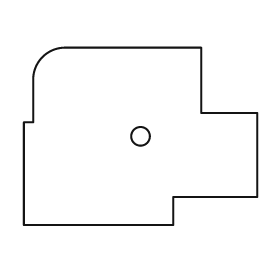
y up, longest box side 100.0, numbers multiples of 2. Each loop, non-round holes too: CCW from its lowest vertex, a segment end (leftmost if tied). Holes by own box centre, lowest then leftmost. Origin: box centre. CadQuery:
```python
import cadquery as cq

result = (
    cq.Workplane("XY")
    .moveTo(-50.0, -38.0)
    .lineTo(14.0, -38.0)
    .lineTo(14.0, -26.0)
    .lineTo(50.0, -26.0)
    .lineTo(50.0, 10.0)
    .lineTo(26.0, 10.0)
    .lineTo(26.0, 38.0)
    .lineTo(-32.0, 38.0)
    .threePointArc((-42.0, 34.0), (-46.0, 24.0))
    .lineTo(-46.0, 6.0)
    .lineTo(-50.0, 6.0)
    .close()
    .moveTo(0.0, 0.0)
    .circle(4.0)
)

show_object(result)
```